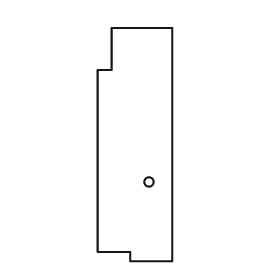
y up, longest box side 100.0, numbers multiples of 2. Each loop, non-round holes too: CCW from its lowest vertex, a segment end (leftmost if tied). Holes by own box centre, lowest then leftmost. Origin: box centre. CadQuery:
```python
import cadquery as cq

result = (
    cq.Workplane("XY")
    .moveTo(-2.0, -50.0)
    .lineTo(16.0, -50.0)
    .lineTo(16.0, 50.0)
    .lineTo(-10.0, 50.0)
    .lineTo(-10.0, 32.0)
    .lineTo(-16.0, 32.0)
    .lineTo(-16.0, -46.0)
    .lineTo(-2.0, -46.0)
    .close()
    .moveTo(6.0, -16.0)
    .circle(2.0)
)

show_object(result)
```